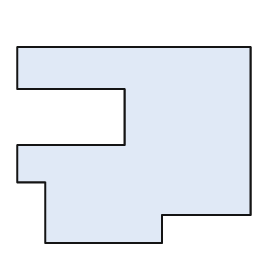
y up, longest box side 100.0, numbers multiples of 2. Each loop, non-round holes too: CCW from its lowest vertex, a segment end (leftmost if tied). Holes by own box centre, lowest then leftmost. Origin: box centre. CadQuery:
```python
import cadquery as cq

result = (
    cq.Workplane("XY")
    .moveTo(-38.0, -42.0)
    .lineTo(12.0, -42.0)
    .lineTo(12.0, -30.0)
    .lineTo(50.0, -30.0)
    .lineTo(50.0, 42.0)
    .lineTo(-50.0, 42.0)
    .lineTo(-50.0, 24.0)
    .lineTo(-4.0, 24.0)
    .lineTo(-4.0, 0.0)
    .lineTo(-50.0, 0.0)
    .lineTo(-50.0, -16.0)
    .lineTo(-38.0, -16.0)
    .close()
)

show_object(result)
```